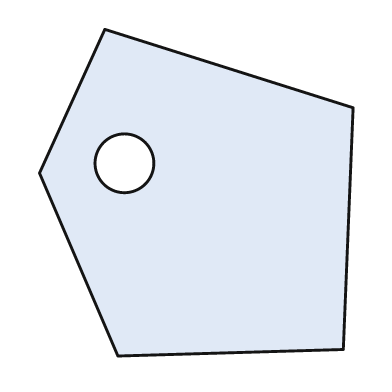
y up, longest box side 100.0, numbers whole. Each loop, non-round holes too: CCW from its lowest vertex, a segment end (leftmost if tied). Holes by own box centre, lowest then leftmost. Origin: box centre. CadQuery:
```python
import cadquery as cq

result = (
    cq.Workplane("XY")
    .moveTo(-24.0, -50.0)
    .lineTo(45.0, -48.0)
    .lineTo(48.0, 26.0)
    .lineTo(-28.0, 50.0)
    .lineTo(-48.0, 6.0)
    .close()
    .moveTo(-22.0, 9.0)
    .circle(9.0)
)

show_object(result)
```